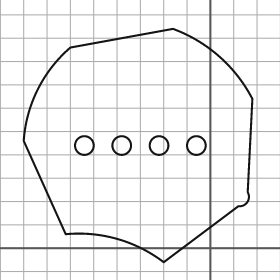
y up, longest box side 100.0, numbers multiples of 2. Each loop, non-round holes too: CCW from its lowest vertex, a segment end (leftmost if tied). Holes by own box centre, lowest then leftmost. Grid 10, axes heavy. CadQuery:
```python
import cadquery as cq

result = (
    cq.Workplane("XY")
    .moveTo(-20.0, -6.0)
    .lineTo(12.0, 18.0)
    .threePointArc((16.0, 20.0), (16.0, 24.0))
    .lineTo(18.0, 64.0)
    .threePointArc((4.0, 82.0), (-16.0, 94.0))
    .lineTo(-60.0, 86.0)
    .threePointArc((-74.0, 68.0), (-80.0, 46.0))
    .lineTo(-62.0, 6.0)
    .threePointArc((-40.0, 4.0), (-20.0, -6.0))
    .close()
    .moveTo(-54.0, 44.0)
    .circle(4.0)
    .moveTo(-38.0, 44.0)
    .circle(4.0)
    .moveTo(-22.0, 44.0)
    .circle(4.0)
    .moveTo(-6.0, 44.0)
    .circle(4.0)
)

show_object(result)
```